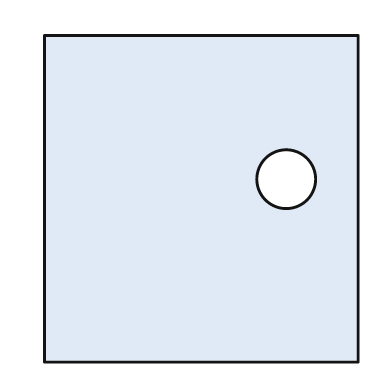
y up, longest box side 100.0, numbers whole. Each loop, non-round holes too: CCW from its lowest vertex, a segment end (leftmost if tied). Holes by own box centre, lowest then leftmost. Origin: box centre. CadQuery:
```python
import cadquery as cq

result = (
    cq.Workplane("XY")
    .moveTo(-48.0, -50.0)
    .lineTo(48.0, -50.0)
    .lineTo(48.0, 50.0)
    .lineTo(-48.0, 50.0)
    .close()
    .moveTo(26.0, 6.0)
    .circle(9.0)
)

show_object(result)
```